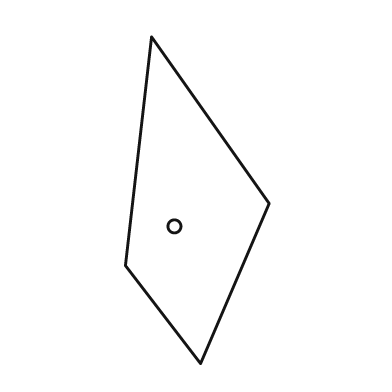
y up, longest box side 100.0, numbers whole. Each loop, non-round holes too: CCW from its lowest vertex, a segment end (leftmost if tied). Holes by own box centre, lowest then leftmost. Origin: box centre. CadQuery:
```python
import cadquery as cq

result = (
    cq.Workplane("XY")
    .moveTo(1.0, -50.0)
    .lineTo(22.0, -1.0)
    .lineTo(-14.0, 50.0)
    .lineTo(-22.0, -20.0)
    .close()
    .moveTo(-7.0, -8.0)
    .circle(2.0)
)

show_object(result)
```